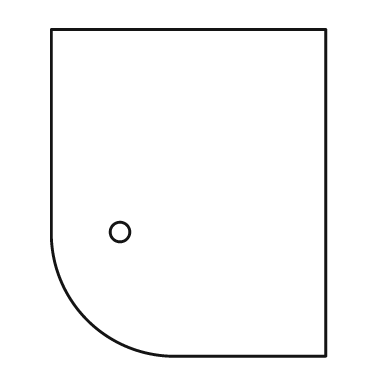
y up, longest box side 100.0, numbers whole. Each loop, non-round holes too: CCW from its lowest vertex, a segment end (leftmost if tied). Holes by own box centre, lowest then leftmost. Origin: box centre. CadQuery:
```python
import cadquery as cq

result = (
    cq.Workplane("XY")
    .moveTo(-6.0, -50.0)
    .lineTo(42.0, -50.0)
    .lineTo(42.0, 50.0)
    .lineTo(-42.0, 50.0)
    .lineTo(-42.0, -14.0)
    .threePointArc((-31.0, -39.0), (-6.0, -50.0))
    .close()
    .moveTo(-21.0, -12.0)
    .circle(3.0)
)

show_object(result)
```